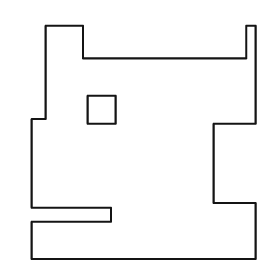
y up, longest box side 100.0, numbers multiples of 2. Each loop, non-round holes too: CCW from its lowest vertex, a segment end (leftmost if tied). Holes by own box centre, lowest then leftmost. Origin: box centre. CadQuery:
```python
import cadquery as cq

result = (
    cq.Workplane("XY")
    .moveTo(-48.0, -50.0)
    .lineTo(48.0, -50.0)
    .lineTo(48.0, -26.0)
    .lineTo(30.0, -26.0)
    .lineTo(30.0, 8.0)
    .lineTo(48.0, 8.0)
    .lineTo(48.0, 50.0)
    .lineTo(44.0, 50.0)
    .lineTo(44.0, 36.0)
    .lineTo(-26.0, 36.0)
    .lineTo(-26.0, 50.0)
    .lineTo(-42.0, 50.0)
    .lineTo(-42.0, 10.0)
    .lineTo(-48.0, 10.0)
    .lineTo(-48.0, -28.0)
    .lineTo(-14.0, -28.0)
    .lineTo(-14.0, -34.0)
    .lineTo(-48.0, -34.0)
    .close()
    .moveTo(-24.0, 8.0)
    .lineTo(-12.0, 8.0)
    .lineTo(-12.0, 20.0)
    .lineTo(-24.0, 20.0)
    .close()
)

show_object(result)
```